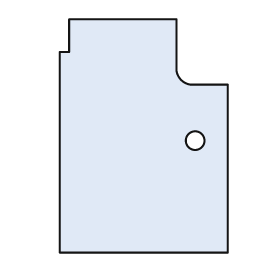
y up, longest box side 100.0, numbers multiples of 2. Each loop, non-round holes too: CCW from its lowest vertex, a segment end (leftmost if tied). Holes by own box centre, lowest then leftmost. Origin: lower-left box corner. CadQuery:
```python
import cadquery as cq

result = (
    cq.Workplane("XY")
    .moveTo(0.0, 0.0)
    .lineTo(72.0, 0.0)
    .lineTo(72.0, 72.0)
    .lineTo(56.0, 72.0)
    .threePointArc((52.0, 74.0), (50.0, 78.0))
    .lineTo(50.0, 100.0)
    .lineTo(4.0, 100.0)
    .lineTo(4.0, 86.0)
    .lineTo(0.0, 86.0)
    .close()
    .moveTo(58.0, 48.0)
    .circle(4.0)
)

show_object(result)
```